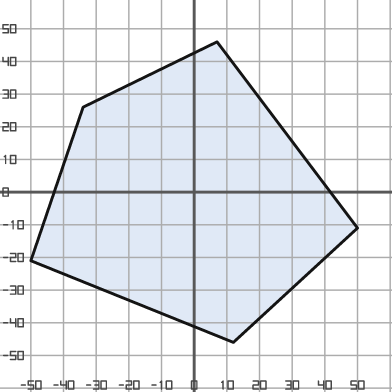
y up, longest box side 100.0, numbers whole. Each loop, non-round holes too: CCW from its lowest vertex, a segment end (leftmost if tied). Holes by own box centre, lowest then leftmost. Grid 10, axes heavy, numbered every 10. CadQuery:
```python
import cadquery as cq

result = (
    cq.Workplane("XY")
    .moveTo(12.0, -46.0)
    .lineTo(50.0, -11.0)
    .lineTo(7.0, 46.0)
    .lineTo(-34.0, 26.0)
    .lineTo(-50.0, -21.0)
    .close()
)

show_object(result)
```